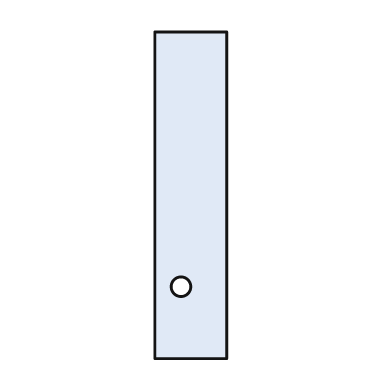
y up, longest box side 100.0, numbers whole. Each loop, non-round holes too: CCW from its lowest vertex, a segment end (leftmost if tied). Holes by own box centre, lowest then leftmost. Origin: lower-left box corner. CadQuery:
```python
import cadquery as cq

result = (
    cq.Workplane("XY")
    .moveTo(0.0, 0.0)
    .lineTo(22.0, 0.0)
    .lineTo(22.0, 100.0)
    .lineTo(0.0, 100.0)
    .close()
    .moveTo(8.0, 22.0)
    .circle(3.0)
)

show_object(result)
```